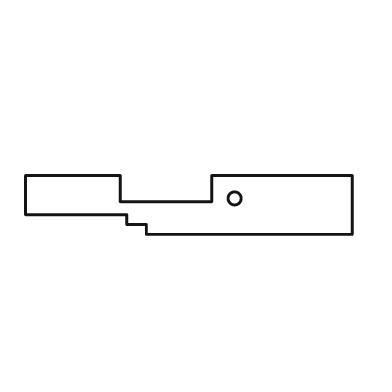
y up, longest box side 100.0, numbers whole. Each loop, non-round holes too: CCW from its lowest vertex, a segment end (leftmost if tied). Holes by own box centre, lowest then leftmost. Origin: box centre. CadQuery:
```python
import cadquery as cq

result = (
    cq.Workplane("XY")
    .moveTo(-13.0, -9.0)
    .lineTo(50.0, -9.0)
    .lineTo(50.0, 9.0)
    .lineTo(7.0, 9.0)
    .lineTo(7.0, 1.0)
    .lineTo(-21.0, 1.0)
    .lineTo(-21.0, 9.0)
    .lineTo(-50.0, 9.0)
    .lineTo(-50.0, -3.0)
    .lineTo(-19.0, -3.0)
    .lineTo(-19.0, -6.0)
    .lineTo(-13.0, -6.0)
    .close()
    .moveTo(14.0, 2.0)
    .circle(2.0)
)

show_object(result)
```